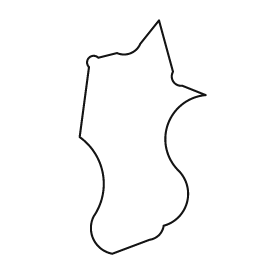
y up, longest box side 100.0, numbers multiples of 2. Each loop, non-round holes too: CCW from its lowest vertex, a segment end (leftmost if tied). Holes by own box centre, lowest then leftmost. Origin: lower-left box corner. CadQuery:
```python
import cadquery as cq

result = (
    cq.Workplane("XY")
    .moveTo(14.0, 0.0)
    .lineTo(30.0, 6.0)
    .threePointArc((34.0, 8.0), (36.0, 12.0))
    .threePointArc((46.0, 22.0), (42.0, 36.0))
    .threePointArc((38.0, 56.0), (54.0, 68.0))
    .lineTo(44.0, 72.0)
    .threePointArc((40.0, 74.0), (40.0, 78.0))
    .lineTo(34.0, 100.0)
    .lineTo(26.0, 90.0)
    .threePointArc((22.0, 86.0), (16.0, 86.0))
    .lineTo(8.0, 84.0)
    .threePointArc((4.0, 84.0), (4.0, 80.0))
    .lineTo(0.0, 50.0)
    .threePointArc((10.0, 34.0), (6.0, 16.0))
    .threePointArc((6.0, 6.0), (14.0, 0.0))
    .close()
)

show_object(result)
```